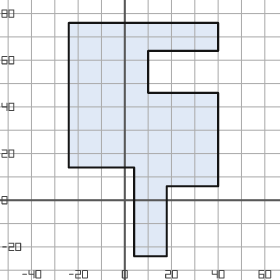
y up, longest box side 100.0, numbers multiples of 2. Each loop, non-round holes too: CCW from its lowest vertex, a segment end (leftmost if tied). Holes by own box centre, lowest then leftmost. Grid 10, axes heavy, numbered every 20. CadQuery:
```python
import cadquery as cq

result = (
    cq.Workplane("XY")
    .moveTo(4.0, -24.0)
    .lineTo(18.0, -24.0)
    .lineTo(18.0, 6.0)
    .lineTo(40.0, 6.0)
    .lineTo(40.0, 46.0)
    .lineTo(10.0, 46.0)
    .lineTo(10.0, 64.0)
    .lineTo(40.0, 64.0)
    .lineTo(40.0, 76.0)
    .lineTo(-24.0, 76.0)
    .lineTo(-24.0, 14.0)
    .lineTo(4.0, 14.0)
    .close()
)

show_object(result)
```